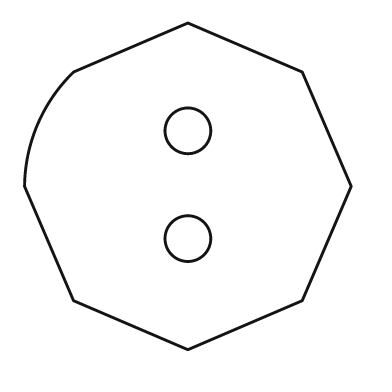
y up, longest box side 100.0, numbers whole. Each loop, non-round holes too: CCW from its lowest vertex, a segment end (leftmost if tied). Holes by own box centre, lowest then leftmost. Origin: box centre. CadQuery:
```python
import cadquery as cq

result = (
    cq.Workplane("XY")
    .moveTo(0.0, -50.0)
    .lineTo(35.0, -35.0)
    .lineTo(50.0, 0.0)
    .lineTo(35.0, 35.0)
    .lineTo(0.0, 50.0)
    .lineTo(-35.0, 35.0)
    .threePointArc((-46.0, 19.0), (-50.0, 0.0))
    .lineTo(-35.0, -35.0)
    .close()
    .moveTo(0.0, -16.0)
    .circle(7.0)
    .moveTo(0.0, 17.0)
    .circle(7.0)
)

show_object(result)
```